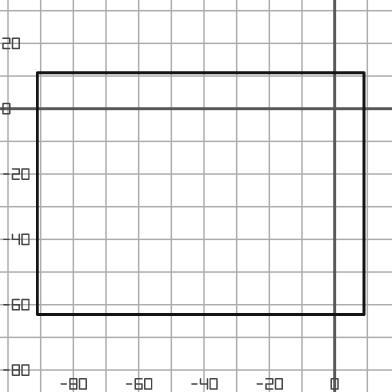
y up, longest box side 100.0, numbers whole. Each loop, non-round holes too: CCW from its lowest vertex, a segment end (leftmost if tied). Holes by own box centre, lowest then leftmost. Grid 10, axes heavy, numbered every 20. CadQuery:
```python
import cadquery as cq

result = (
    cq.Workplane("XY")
    .moveTo(-91.0, -63.0)
    .lineTo(9.0, -63.0)
    .lineTo(9.0, 11.0)
    .lineTo(-91.0, 11.0)
    .close()
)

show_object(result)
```